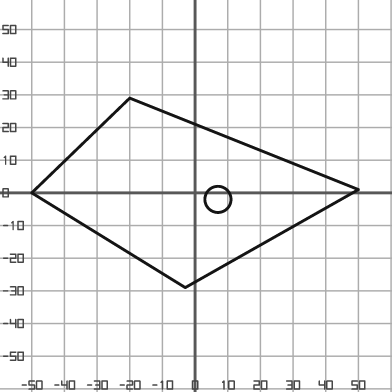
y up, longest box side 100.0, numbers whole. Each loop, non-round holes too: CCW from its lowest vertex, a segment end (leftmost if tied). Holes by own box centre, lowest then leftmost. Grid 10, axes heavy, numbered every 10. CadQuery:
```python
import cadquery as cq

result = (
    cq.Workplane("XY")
    .moveTo(-3.0, -29.0)
    .lineTo(50.0, 1.0)
    .lineTo(-20.0, 29.0)
    .lineTo(-50.0, 0.0)
    .close()
    .moveTo(7.0, -2.0)
    .circle(4.0)
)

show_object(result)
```